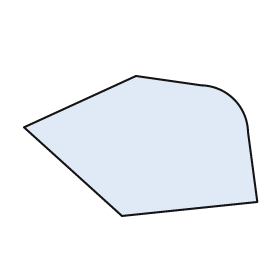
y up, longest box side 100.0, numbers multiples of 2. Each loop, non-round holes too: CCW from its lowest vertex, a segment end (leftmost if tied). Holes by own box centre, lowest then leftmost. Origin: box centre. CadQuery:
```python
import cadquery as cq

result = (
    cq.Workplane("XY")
    .moveTo(-8.0, -30.0)
    .lineTo(50.0, -24.0)
    .lineTo(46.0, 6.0)
    .threePointArc((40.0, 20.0), (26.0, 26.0))
    .lineTo(-2.0, 30.0)
    .lineTo(-50.0, 8.0)
    .close()
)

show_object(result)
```